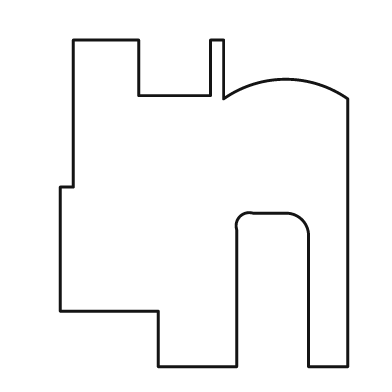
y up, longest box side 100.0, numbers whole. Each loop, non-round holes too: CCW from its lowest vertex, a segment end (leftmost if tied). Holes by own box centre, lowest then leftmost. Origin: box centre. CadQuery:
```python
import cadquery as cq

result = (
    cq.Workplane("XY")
    .moveTo(-14.0, -50.0)
    .lineTo(10.0, -50.0)
    .lineTo(10.0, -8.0)
    .threePointArc((11.0, -4.0), (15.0, -3.0))
    .lineTo(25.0, -3.0)
    .threePointArc((30.0, -5.0), (32.0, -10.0))
    .lineTo(32.0, -50.0)
    .lineTo(44.0, -50.0)
    .lineTo(44.0, 32.0)
    .threePointArc((25.0, 38.0), (6.0, 32.0))
    .lineTo(6.0, 50.0)
    .lineTo(2.0, 50.0)
    .lineTo(2.0, 33.0)
    .lineTo(-20.0, 33.0)
    .lineTo(-20.0, 50.0)
    .lineTo(-40.0, 50.0)
    .lineTo(-40.0, 5.0)
    .lineTo(-44.0, 5.0)
    .lineTo(-44.0, -33.0)
    .lineTo(-14.0, -33.0)
    .close()
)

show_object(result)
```